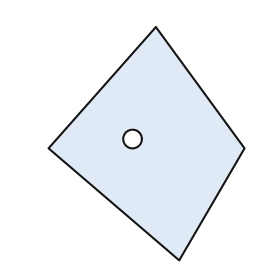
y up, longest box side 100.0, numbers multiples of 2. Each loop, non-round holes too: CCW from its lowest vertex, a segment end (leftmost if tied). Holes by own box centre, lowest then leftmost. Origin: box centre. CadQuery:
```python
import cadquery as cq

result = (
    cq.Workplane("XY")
    .moveTo(14.0, -50.0)
    .lineTo(42.0, -2.0)
    .lineTo(4.0, 50.0)
    .lineTo(-42.0, -2.0)
    .close()
    .moveTo(-6.0, 2.0)
    .circle(4.0)
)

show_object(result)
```